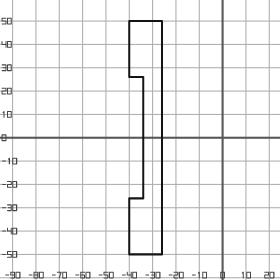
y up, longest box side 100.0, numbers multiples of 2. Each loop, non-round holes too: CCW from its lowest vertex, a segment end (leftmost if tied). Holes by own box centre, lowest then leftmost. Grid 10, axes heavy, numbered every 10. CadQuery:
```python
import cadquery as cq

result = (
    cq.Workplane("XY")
    .moveTo(-40.0, -50.0)
    .lineTo(-26.0, -50.0)
    .lineTo(-26.0, 50.0)
    .lineTo(-40.0, 50.0)
    .lineTo(-40.0, 26.0)
    .lineTo(-34.0, 26.0)
    .lineTo(-34.0, -26.0)
    .lineTo(-40.0, -26.0)
    .close()
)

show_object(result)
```